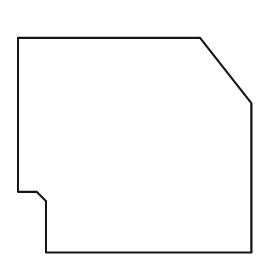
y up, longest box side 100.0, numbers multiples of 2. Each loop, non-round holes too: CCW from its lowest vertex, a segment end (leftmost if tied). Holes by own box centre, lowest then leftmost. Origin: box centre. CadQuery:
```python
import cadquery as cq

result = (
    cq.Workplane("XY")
    .moveTo(-38.0, -46.0)
    .lineTo(50.0, -46.0)
    .lineTo(50.0, 18.0)
    .lineTo(28.0, 46.0)
    .lineTo(-50.0, 46.0)
    .lineTo(-50.0, -20.0)
    .lineTo(-42.0, -20.0)
    .lineTo(-38.0, -24.0)
    .close()
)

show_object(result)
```